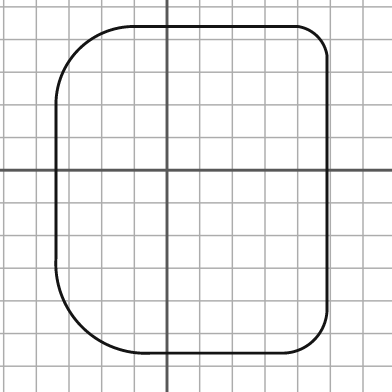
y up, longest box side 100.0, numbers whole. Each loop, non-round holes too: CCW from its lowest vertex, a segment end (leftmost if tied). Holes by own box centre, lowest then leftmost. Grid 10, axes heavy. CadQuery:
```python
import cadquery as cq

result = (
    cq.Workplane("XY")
    .moveTo(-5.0, -56.0)
    .lineTo(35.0, -56.0)
    .threePointArc((45.0, -52.0), (49.0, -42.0))
    .lineTo(49.0, 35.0)
    .threePointArc((46.0, 41.0), (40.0, 44.0))
    .lineTo(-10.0, 44.0)
    .threePointArc((-27.0, 37.0), (-34.0, 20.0))
    .lineTo(-34.0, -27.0)
    .threePointArc((-26.0, -48.0), (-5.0, -56.0))
    .close()
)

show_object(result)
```